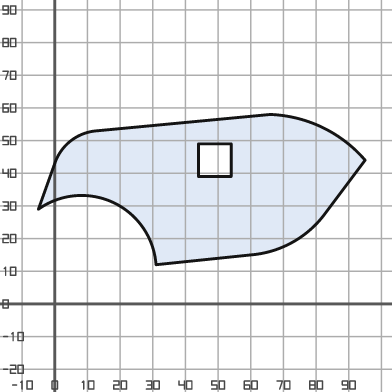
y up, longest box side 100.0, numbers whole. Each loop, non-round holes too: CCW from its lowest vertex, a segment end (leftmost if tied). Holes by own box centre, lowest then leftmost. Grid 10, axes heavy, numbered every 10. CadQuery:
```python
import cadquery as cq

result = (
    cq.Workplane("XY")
    .moveTo(31.0, 12.0)
    .lineTo(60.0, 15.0)
    .threePointArc((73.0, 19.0), (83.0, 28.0))
    .lineTo(95.0, 44.0)
    .threePointArc((82.0, 54.0), (66.0, 58.0))
    .lineTo(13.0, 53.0)
    .threePointArc((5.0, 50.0), (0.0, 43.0))
    .lineTo(-5.0, 29.0)
    .threePointArc((18.0, 31.0), (31.0, 12.0))
    .close()
    .moveTo(44.0, 39.0)
    .lineTo(54.0, 39.0)
    .lineTo(54.0, 49.0)
    .lineTo(44.0, 49.0)
    .close()
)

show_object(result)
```